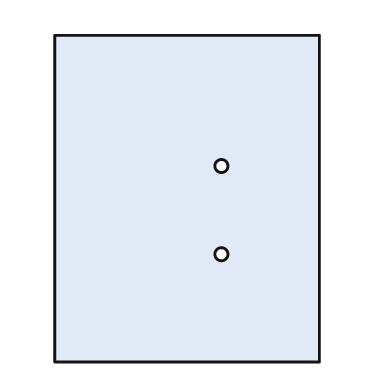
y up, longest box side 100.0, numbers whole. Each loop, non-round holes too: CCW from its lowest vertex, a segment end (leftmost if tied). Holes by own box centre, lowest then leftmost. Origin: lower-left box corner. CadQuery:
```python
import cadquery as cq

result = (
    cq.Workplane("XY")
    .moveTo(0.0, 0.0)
    .lineTo(81.0, 0.0)
    .lineTo(81.0, 100.0)
    .lineTo(0.0, 100.0)
    .close()
    .moveTo(51.0, 33.0)
    .circle(2.0)
    .moveTo(51.0, 60.0)
    .circle(2.0)
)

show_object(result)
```